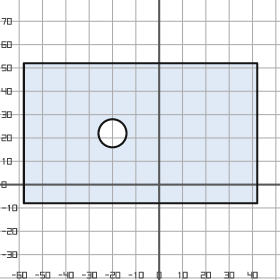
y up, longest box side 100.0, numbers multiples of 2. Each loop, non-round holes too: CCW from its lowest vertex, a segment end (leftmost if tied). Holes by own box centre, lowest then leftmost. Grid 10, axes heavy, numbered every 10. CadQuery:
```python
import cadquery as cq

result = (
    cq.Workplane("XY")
    .moveTo(-58.0, -8.0)
    .lineTo(42.0, -8.0)
    .lineTo(42.0, 52.0)
    .lineTo(-58.0, 52.0)
    .close()
    .moveTo(-20.0, 22.0)
    .circle(6.0)
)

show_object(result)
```